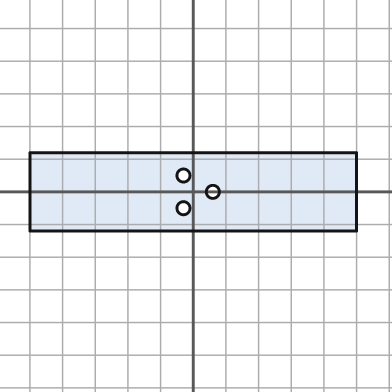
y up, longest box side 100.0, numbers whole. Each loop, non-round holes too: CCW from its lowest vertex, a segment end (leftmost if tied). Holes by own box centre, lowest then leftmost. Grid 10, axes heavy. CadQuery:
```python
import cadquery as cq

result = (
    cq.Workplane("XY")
    .moveTo(-50.0, -12.0)
    .lineTo(50.0, -12.0)
    .lineTo(50.0, 12.0)
    .lineTo(-50.0, 12.0)
    .close()
    .moveTo(-3.0, -5.0)
    .circle(2.0)
    .moveTo(6.0, 0.0)
    .circle(2.0)
    .moveTo(-3.0, 5.0)
    .circle(2.0)
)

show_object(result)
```